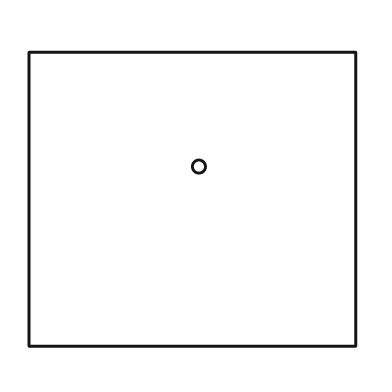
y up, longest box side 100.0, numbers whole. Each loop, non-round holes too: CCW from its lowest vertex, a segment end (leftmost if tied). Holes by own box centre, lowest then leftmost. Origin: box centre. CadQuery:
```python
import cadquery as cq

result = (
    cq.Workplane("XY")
    .moveTo(-50.0, -45.0)
    .lineTo(50.0, -45.0)
    .lineTo(50.0, 45.0)
    .lineTo(-50.0, 45.0)
    .close()
    .moveTo(2.0, 10.0)
    .circle(2.0)
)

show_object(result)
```